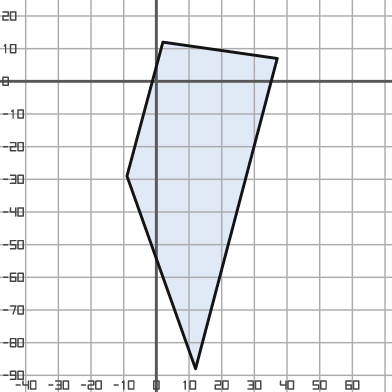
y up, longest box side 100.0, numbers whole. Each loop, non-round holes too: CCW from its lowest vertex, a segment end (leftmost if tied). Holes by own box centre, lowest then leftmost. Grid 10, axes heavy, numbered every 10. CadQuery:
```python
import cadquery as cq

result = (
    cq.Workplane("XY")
    .moveTo(12.0, -88.0)
    .lineTo(37.0, 7.0)
    .lineTo(2.0, 12.0)
    .lineTo(-9.0, -29.0)
    .close()
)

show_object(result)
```